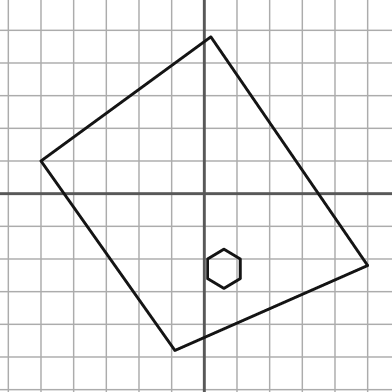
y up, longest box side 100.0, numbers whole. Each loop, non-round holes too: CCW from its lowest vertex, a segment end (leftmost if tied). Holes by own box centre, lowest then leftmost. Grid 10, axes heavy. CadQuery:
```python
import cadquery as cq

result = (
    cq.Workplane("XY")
    .moveTo(-9.0, -48.0)
    .lineTo(50.0, -22.0)
    .lineTo(2.0, 48.0)
    .lineTo(-50.0, 10.0)
    .close()
    .moveTo(6.0, -29.0)
    .lineTo(11.0, -26.0)
    .lineTo(11.0, -20.0)
    .lineTo(6.0, -17.0)
    .lineTo(1.0, -20.0)
    .lineTo(1.0, -26.0)
    .close()
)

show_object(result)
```